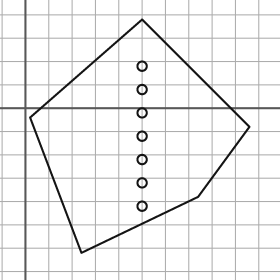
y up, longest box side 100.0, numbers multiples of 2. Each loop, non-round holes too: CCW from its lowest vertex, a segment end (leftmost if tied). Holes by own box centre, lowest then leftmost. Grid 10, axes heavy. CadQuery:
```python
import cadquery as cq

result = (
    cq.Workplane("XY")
    .moveTo(24.0, -62.0)
    .lineTo(74.0, -38.0)
    .lineTo(96.0, -8.0)
    .lineTo(50.0, 38.0)
    .lineTo(2.0, -4.0)
    .close()
    .moveTo(50.0, -42.0)
    .circle(2.0)
    .moveTo(50.0, -32.0)
    .circle(2.0)
    .moveTo(50.0, -22.0)
    .circle(2.0)
    .moveTo(50.0, -12.0)
    .circle(2.0)
    .moveTo(50.0, -2.0)
    .circle(2.0)
    .moveTo(50.0, 8.0)
    .circle(2.0)
    .moveTo(50.0, 18.0)
    .circle(2.0)
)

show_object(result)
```